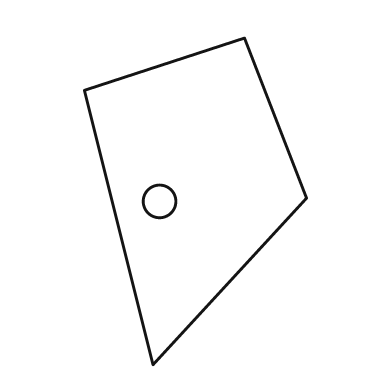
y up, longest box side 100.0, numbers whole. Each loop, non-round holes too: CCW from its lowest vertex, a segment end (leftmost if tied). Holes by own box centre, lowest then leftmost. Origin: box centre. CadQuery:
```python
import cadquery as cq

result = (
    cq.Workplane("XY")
    .moveTo(-13.0, -50.0)
    .lineTo(34.0, 1.0)
    .lineTo(15.0, 50.0)
    .lineTo(-34.0, 34.0)
    .close()
    .moveTo(-11.0, 0.0)
    .circle(5.0)
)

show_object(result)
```